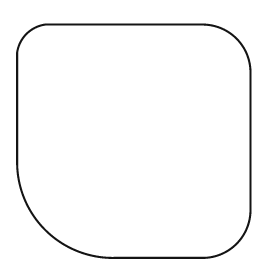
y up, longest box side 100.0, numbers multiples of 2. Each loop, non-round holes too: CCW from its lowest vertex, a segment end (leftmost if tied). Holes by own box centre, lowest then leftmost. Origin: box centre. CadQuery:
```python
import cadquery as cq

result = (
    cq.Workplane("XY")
    .moveTo(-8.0, -50.0)
    .lineTo(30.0, -50.0)
    .threePointArc((44.0, -44.0), (50.0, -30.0))
    .lineTo(50.0, 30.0)
    .threePointArc((44.0, 44.0), (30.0, 50.0))
    .lineTo(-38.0, 50.0)
    .threePointArc((-46.0, 46.0), (-50.0, 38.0))
    .lineTo(-50.0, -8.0)
    .threePointArc((-38.0, -38.0), (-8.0, -50.0))
    .close()
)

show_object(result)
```